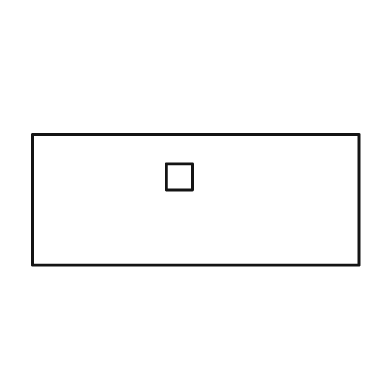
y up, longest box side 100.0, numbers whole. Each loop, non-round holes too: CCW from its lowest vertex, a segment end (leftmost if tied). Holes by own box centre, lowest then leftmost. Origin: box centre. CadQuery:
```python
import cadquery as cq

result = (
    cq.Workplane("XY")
    .moveTo(-50.0, -20.0)
    .lineTo(50.0, -20.0)
    .lineTo(50.0, 20.0)
    .lineTo(-50.0, 20.0)
    .close()
    .moveTo(-9.0, 3.0)
    .lineTo(-1.0, 3.0)
    .lineTo(-1.0, 11.0)
    .lineTo(-9.0, 11.0)
    .close()
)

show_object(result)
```